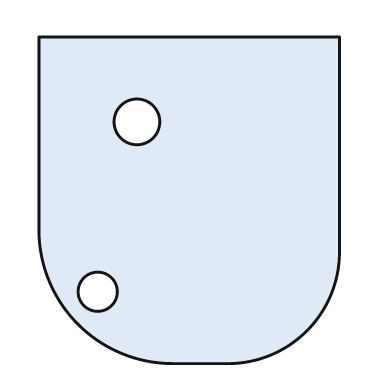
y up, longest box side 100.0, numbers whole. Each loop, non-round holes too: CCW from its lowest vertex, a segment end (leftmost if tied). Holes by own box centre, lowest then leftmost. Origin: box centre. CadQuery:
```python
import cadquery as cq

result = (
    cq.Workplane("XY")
    .moveTo(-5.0, -50.0)
    .lineTo(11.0, -50.0)
    .threePointArc((36.0, -40.0), (46.0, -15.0))
    .lineTo(46.0, 50.0)
    .lineTo(-46.0, 50.0)
    .lineTo(-46.0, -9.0)
    .threePointArc((-34.0, -38.0), (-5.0, -50.0))
    .close()
    .moveTo(-28.0, -28.0)
    .circle(6.0)
    .moveTo(-16.0, 24.0)
    .circle(7.0)
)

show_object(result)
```